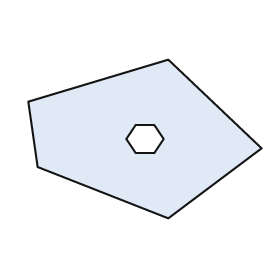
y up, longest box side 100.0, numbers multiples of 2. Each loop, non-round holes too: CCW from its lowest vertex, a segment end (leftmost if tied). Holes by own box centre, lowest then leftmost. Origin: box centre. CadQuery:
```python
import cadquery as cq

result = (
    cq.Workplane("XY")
    .moveTo(10.0, -34.0)
    .lineTo(50.0, -4.0)
    .lineTo(10.0, 34.0)
    .lineTo(-50.0, 16.0)
    .lineTo(-46.0, -12.0)
    .close()
    .moveTo(-4.0, -6.0)
    .lineTo(4.0, -6.0)
    .lineTo(8.0, 0.0)
    .lineTo(4.0, 6.0)
    .lineTo(-4.0, 6.0)
    .lineTo(-8.0, 0.0)
    .close()
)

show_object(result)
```